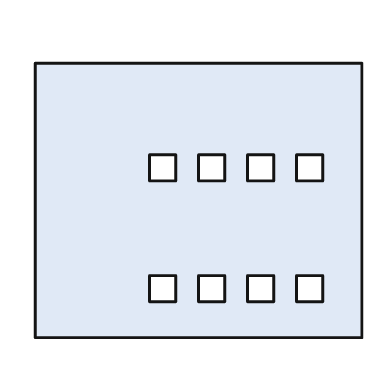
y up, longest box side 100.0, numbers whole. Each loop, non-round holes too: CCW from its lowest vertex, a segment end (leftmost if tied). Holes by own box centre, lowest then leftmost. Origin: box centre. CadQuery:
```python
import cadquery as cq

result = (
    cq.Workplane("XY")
    .moveTo(-50.0, -42.0)
    .lineTo(50.0, -42.0)
    .lineTo(50.0, 42.0)
    .lineTo(-50.0, 42.0)
    .close()
    .moveTo(-15.0, -31.0)
    .lineTo(-7.0, -31.0)
    .lineTo(-7.0, -23.0)
    .lineTo(-15.0, -23.0)
    .close()
    .moveTo(0.0, -31.0)
    .lineTo(8.0, -31.0)
    .lineTo(8.0, -23.0)
    .lineTo(0.0, -23.0)
    .close()
    .moveTo(15.0, -31.0)
    .lineTo(23.0, -31.0)
    .lineTo(23.0, -23.0)
    .lineTo(15.0, -23.0)
    .close()
    .moveTo(30.0, -31.0)
    .lineTo(38.0, -31.0)
    .lineTo(38.0, -23.0)
    .lineTo(30.0, -23.0)
    .close()
    .moveTo(-15.0, 6.0)
    .lineTo(-7.0, 6.0)
    .lineTo(-7.0, 14.0)
    .lineTo(-15.0, 14.0)
    .close()
    .moveTo(0.0, 6.0)
    .lineTo(8.0, 6.0)
    .lineTo(8.0, 14.0)
    .lineTo(0.0, 14.0)
    .close()
    .moveTo(15.0, 6.0)
    .lineTo(23.0, 6.0)
    .lineTo(23.0, 14.0)
    .lineTo(15.0, 14.0)
    .close()
    .moveTo(30.0, 6.0)
    .lineTo(38.0, 6.0)
    .lineTo(38.0, 14.0)
    .lineTo(30.0, 14.0)
    .close()
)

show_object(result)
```